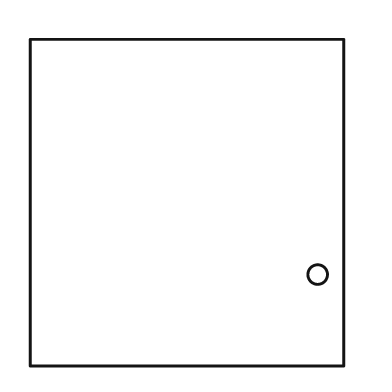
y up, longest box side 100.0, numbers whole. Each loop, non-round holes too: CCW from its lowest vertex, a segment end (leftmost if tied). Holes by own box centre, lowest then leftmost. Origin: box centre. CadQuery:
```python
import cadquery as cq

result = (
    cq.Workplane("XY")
    .moveTo(-48.0, -50.0)
    .lineTo(48.0, -50.0)
    .lineTo(48.0, 50.0)
    .lineTo(-48.0, 50.0)
    .close()
    .moveTo(40.0, -22.0)
    .circle(3.0)
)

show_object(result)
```